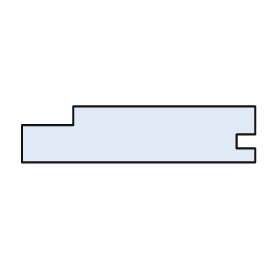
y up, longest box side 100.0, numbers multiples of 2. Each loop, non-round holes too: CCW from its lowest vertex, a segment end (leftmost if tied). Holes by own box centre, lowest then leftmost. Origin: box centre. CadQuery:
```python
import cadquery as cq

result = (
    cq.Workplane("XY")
    .moveTo(-50.0, -12.0)
    .lineTo(50.0, -12.0)
    .lineTo(50.0, -6.0)
    .lineTo(42.0, -6.0)
    .lineTo(42.0, 0.0)
    .lineTo(50.0, 0.0)
    .lineTo(50.0, 12.0)
    .lineTo(-28.0, 12.0)
    .lineTo(-28.0, 4.0)
    .lineTo(-50.0, 4.0)
    .close()
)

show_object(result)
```